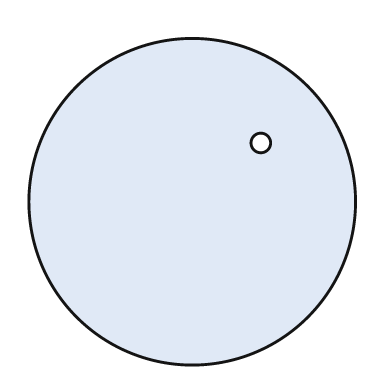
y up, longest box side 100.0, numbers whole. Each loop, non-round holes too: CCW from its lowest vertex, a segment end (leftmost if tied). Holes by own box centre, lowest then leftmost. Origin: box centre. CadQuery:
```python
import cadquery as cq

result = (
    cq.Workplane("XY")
    .moveTo(0.0, 0.0)
    .circle(50.0)
    .moveTo(21.0, 18.0)
    .circle(3.0)
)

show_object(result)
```